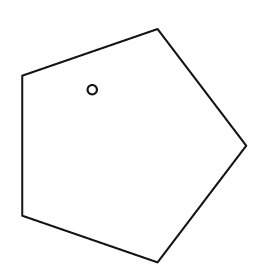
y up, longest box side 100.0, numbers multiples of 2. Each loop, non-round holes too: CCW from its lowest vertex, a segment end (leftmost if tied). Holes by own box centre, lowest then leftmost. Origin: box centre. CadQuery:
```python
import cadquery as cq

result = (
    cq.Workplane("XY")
    .moveTo(10.0, -50.0)
    .lineTo(48.0, 0.0)
    .lineTo(10.0, 50.0)
    .lineTo(-48.0, 30.0)
    .lineTo(-48.0, -30.0)
    .close()
    .moveTo(-18.0, 24.0)
    .circle(2.0)
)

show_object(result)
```